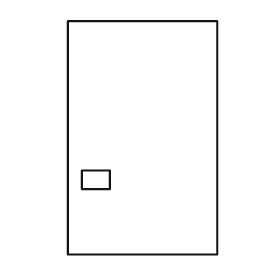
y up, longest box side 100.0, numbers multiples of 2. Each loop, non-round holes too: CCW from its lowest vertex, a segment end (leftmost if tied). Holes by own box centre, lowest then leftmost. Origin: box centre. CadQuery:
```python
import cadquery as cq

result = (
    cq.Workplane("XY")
    .moveTo(-32.0, -50.0)
    .lineTo(32.0, -50.0)
    .lineTo(32.0, 50.0)
    .lineTo(-32.0, 50.0)
    .close()
    .moveTo(-26.0, -22.0)
    .lineTo(-14.0, -22.0)
    .lineTo(-14.0, -14.0)
    .lineTo(-26.0, -14.0)
    .close()
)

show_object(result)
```